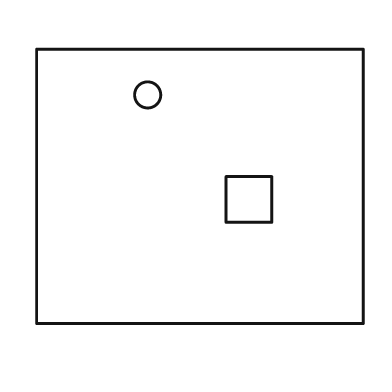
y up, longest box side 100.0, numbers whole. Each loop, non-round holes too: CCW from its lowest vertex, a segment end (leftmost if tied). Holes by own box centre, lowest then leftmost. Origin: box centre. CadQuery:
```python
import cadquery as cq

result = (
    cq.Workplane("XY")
    .moveTo(-50.0, -42.0)
    .lineTo(50.0, -42.0)
    .lineTo(50.0, 42.0)
    .lineTo(-50.0, 42.0)
    .close()
    .moveTo(8.0, -11.0)
    .lineTo(22.0, -11.0)
    .lineTo(22.0, 3.0)
    .lineTo(8.0, 3.0)
    .close()
    .moveTo(-16.0, 28.0)
    .circle(4.0)
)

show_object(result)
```